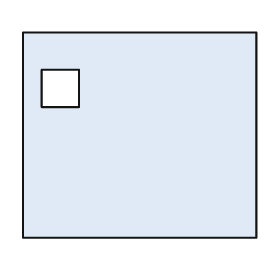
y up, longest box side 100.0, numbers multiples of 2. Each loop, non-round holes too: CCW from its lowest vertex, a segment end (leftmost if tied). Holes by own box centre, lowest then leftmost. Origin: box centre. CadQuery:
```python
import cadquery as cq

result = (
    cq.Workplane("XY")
    .moveTo(-50.0, -44.0)
    .lineTo(50.0, -44.0)
    .lineTo(50.0, 44.0)
    .lineTo(-50.0, 44.0)
    .close()
    .moveTo(-42.0, 12.0)
    .lineTo(-26.0, 12.0)
    .lineTo(-26.0, 28.0)
    .lineTo(-42.0, 28.0)
    .close()
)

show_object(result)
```